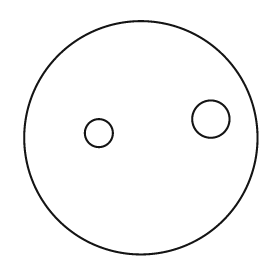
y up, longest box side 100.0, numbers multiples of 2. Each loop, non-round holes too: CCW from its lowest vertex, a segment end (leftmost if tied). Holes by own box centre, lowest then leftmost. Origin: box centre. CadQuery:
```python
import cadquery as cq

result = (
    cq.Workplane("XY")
    .moveTo(0.0, 0.0)
    .circle(50.0)
    .moveTo(-18.0, 2.0)
    .circle(6.0)
    .moveTo(30.0, 8.0)
    .circle(8.0)
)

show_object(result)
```